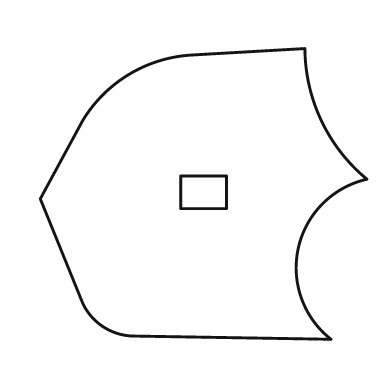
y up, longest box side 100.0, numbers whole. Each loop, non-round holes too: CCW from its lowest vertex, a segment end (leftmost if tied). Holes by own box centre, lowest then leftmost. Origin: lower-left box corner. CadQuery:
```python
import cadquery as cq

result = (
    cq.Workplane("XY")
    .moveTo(89.0, 0.0)
    .threePointArc((79.0, 28.0), (100.0, 49.0))
    .threePointArc((86.0, 67.0), (81.0, 89.0))
    .lineTo(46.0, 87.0)
    .threePointArc((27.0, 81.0), (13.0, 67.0))
    .lineTo(0.0, 43.0)
    .lineTo(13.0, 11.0)
    .threePointArc((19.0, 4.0), (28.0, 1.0))
    .close()
    .moveTo(43.0, 40.0)
    .lineTo(57.0, 40.0)
    .lineTo(57.0, 50.0)
    .lineTo(43.0, 50.0)
    .close()
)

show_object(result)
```